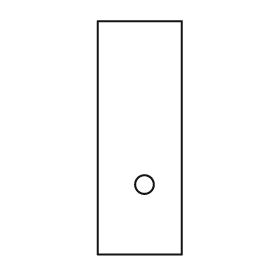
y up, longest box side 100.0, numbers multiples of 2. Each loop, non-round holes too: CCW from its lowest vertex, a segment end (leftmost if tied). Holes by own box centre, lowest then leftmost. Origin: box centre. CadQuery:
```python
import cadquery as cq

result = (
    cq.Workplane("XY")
    .moveTo(-18.0, -50.0)
    .lineTo(18.0, -50.0)
    .lineTo(18.0, 50.0)
    .lineTo(-18.0, 50.0)
    .close()
    .moveTo(2.0, -20.0)
    .circle(4.0)
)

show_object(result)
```